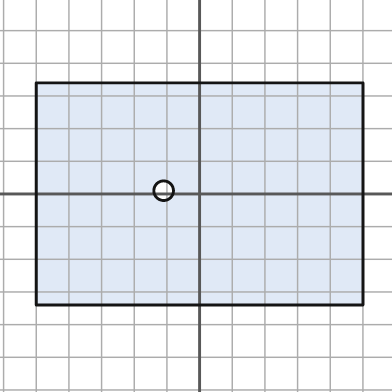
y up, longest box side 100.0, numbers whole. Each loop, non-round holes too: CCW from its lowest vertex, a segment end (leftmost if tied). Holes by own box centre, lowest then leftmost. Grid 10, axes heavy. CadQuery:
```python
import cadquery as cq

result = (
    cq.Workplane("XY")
    .moveTo(-50.0, -34.0)
    .lineTo(50.0, -34.0)
    .lineTo(50.0, 34.0)
    .lineTo(-50.0, 34.0)
    .close()
    .moveTo(-11.0, 1.0)
    .circle(3.0)
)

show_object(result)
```